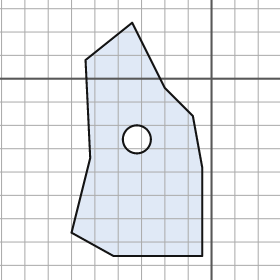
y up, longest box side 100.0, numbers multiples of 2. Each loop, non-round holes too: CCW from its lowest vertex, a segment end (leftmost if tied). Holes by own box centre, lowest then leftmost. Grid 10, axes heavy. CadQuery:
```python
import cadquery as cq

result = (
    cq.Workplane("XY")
    .moveTo(-42.0, -76.0)
    .lineTo(-4.0, -76.0)
    .lineTo(-4.0, -38.0)
    .lineTo(-8.0, -16.0)
    .lineTo(-20.0, -4.0)
    .lineTo(-34.0, 24.0)
    .lineTo(-54.0, 8.0)
    .lineTo(-52.0, -34.0)
    .lineTo(-60.0, -66.0)
    .close()
    .moveTo(-32.0, -26.0)
    .circle(6.0)
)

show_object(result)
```